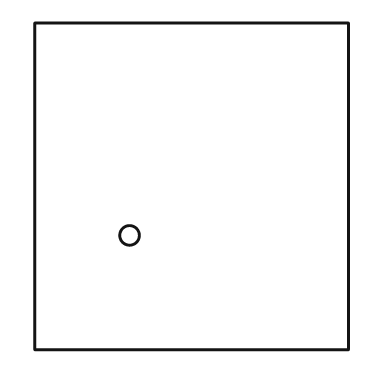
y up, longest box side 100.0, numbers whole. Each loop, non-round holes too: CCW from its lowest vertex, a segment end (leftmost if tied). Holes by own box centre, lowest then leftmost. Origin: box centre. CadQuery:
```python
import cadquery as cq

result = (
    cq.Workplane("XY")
    .moveTo(-48.0, -50.0)
    .lineTo(48.0, -50.0)
    .lineTo(48.0, 50.0)
    .lineTo(-48.0, 50.0)
    .close()
    .moveTo(-19.0, -15.0)
    .circle(3.0)
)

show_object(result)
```